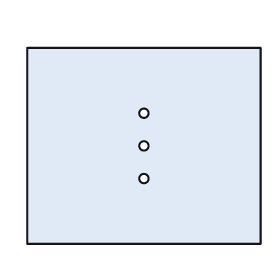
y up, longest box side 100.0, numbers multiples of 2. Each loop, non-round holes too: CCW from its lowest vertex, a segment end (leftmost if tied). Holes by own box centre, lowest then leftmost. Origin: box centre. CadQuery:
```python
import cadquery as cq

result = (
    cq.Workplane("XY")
    .moveTo(-50.0, -42.0)
    .lineTo(50.0, -42.0)
    .lineTo(50.0, 42.0)
    .lineTo(-50.0, 42.0)
    .close()
    .moveTo(0.0, -14.0)
    .circle(2.0)
    .moveTo(0.0, 0.0)
    .circle(2.0)
    .moveTo(0.0, 14.0)
    .circle(2.0)
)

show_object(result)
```